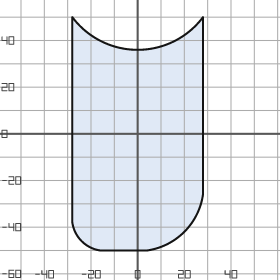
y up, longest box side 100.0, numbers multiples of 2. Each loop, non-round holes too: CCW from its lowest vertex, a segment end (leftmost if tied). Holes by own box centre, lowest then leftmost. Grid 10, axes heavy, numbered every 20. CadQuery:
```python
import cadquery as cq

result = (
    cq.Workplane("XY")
    .moveTo(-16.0, -50.0)
    .lineTo(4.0, -50.0)
    .threePointArc((20.0, -42.0), (28.0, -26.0))
    .lineTo(28.0, 50.0)
    .threePointArc((0.0, 36.0), (-28.0, 50.0))
    .lineTo(-28.0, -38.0)
    .threePointArc((-24.0, -46.0), (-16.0, -50.0))
    .close()
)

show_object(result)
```